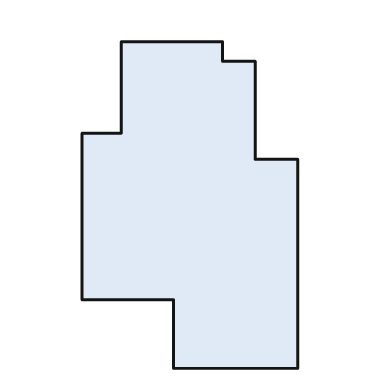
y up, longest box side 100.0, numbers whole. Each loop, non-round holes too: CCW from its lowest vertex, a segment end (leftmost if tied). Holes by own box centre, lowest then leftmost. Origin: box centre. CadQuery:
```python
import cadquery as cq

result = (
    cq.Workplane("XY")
    .moveTo(-5.0, -50.0)
    .lineTo(33.0, -50.0)
    .lineTo(33.0, 14.0)
    .lineTo(20.0, 14.0)
    .lineTo(20.0, 44.0)
    .lineTo(10.0, 44.0)
    .lineTo(10.0, 50.0)
    .lineTo(-21.0, 50.0)
    .lineTo(-21.0, 22.0)
    .lineTo(-33.0, 22.0)
    .lineTo(-33.0, -29.0)
    .lineTo(-5.0, -29.0)
    .close()
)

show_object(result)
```